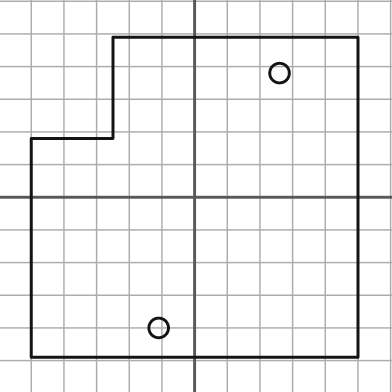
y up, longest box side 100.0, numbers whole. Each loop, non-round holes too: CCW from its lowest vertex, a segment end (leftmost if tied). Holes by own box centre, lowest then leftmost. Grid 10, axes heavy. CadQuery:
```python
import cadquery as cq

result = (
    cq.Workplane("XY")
    .moveTo(-50.0, -49.0)
    .lineTo(50.0, -49.0)
    .lineTo(50.0, 49.0)
    .lineTo(-25.0, 49.0)
    .lineTo(-25.0, 18.0)
    .lineTo(-50.0, 18.0)
    .close()
    .moveTo(-11.0, -40.0)
    .circle(3.0)
    .moveTo(26.0, 38.0)
    .circle(3.0)
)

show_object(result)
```